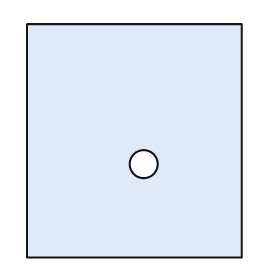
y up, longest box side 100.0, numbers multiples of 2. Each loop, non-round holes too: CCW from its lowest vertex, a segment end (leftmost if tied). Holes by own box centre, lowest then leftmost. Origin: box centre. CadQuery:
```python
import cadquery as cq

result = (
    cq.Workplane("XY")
    .moveTo(-46.0, -50.0)
    .lineTo(46.0, -50.0)
    .lineTo(46.0, 50.0)
    .lineTo(-46.0, 50.0)
    .close()
    .moveTo(4.0, -10.0)
    .circle(6.0)
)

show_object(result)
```